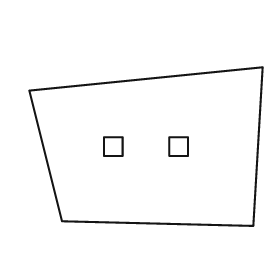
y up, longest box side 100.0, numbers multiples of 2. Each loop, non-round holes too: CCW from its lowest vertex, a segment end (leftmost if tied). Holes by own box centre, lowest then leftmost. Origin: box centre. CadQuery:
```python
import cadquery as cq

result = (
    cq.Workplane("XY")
    .moveTo(46.0, -34.0)
    .lineTo(50.0, 34.0)
    .lineTo(-50.0, 24.0)
    .lineTo(-36.0, -32.0)
    .close()
    .moveTo(-18.0, -4.0)
    .lineTo(-10.0, -4.0)
    .lineTo(-10.0, 4.0)
    .lineTo(-18.0, 4.0)
    .close()
    .moveTo(10.0, -4.0)
    .lineTo(18.0, -4.0)
    .lineTo(18.0, 4.0)
    .lineTo(10.0, 4.0)
    .close()
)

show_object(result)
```